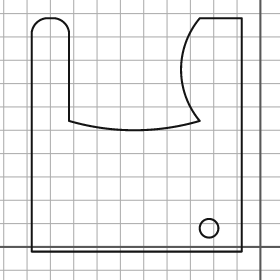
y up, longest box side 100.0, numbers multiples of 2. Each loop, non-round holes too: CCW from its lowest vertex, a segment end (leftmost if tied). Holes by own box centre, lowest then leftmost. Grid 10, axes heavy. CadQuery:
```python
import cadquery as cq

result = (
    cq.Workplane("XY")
    .moveTo(-98.0, -2.0)
    .lineTo(-8.0, -2.0)
    .lineTo(-8.0, 98.0)
    .lineTo(-26.0, 98.0)
    .threePointArc((-34.0, 76.0), (-26.0, 54.0))
    .threePointArc((-54.0, 50.0), (-82.0, 54.0))
    .lineTo(-82.0, 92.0)
    .threePointArc((-84.0, 96.0), (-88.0, 98.0))
    .lineTo(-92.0, 98.0)
    .threePointArc((-96.0, 96.0), (-98.0, 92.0))
    .close()
    .moveTo(-22.0, 8.0)
    .circle(4.0)
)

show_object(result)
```